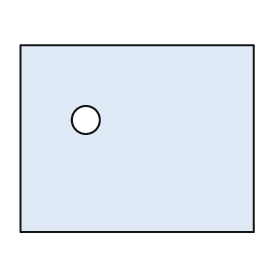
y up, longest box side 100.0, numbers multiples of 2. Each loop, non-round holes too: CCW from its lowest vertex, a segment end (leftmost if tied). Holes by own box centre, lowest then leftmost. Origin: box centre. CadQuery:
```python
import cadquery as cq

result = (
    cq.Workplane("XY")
    .moveTo(-50.0, -40.0)
    .lineTo(50.0, -40.0)
    .lineTo(50.0, 40.0)
    .lineTo(-50.0, 40.0)
    .close()
    .moveTo(-22.0, 8.0)
    .circle(6.0)
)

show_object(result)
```